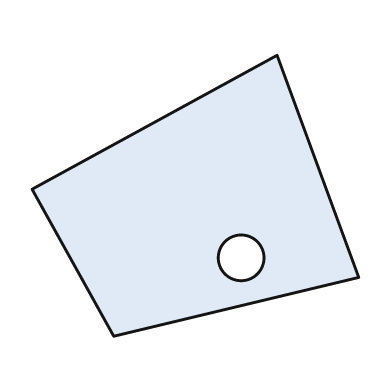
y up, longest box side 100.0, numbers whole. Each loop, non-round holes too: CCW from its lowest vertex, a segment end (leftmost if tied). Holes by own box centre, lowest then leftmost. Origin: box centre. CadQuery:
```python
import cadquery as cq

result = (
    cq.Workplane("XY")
    .moveTo(-25.0, -43.0)
    .lineTo(50.0, -25.0)
    .lineTo(25.0, 43.0)
    .lineTo(-50.0, 2.0)
    .close()
    .moveTo(14.0, -19.0)
    .circle(7.0)
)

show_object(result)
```